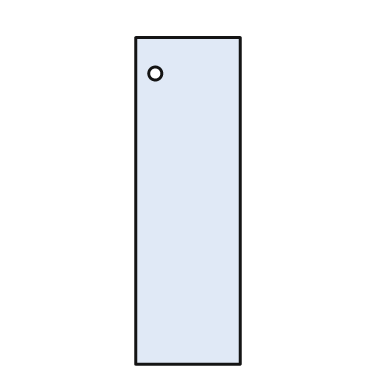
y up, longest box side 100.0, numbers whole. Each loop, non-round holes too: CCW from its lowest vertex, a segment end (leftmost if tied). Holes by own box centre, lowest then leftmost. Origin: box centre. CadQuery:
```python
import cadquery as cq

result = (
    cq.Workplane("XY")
    .moveTo(-16.0, -50.0)
    .lineTo(16.0, -50.0)
    .lineTo(16.0, 50.0)
    .lineTo(-16.0, 50.0)
    .close()
    .moveTo(-10.0, 39.0)
    .circle(2.0)
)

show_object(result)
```